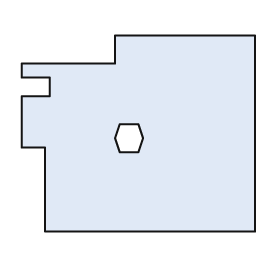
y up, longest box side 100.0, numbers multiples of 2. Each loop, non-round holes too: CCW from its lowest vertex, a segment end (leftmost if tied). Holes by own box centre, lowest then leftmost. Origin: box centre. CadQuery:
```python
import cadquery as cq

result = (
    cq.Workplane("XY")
    .moveTo(-40.0, -42.0)
    .lineTo(50.0, -42.0)
    .lineTo(50.0, 42.0)
    .lineTo(-10.0, 42.0)
    .lineTo(-10.0, 30.0)
    .lineTo(-50.0, 30.0)
    .lineTo(-50.0, 24.0)
    .lineTo(-38.0, 24.0)
    .lineTo(-38.0, 16.0)
    .lineTo(-50.0, 16.0)
    .lineTo(-50.0, -6.0)
    .lineTo(-40.0, -6.0)
    .close()
    .moveTo(-8.0, -8.0)
    .lineTo(0.0, -8.0)
    .lineTo(2.0, -2.0)
    .lineTo(0.0, 4.0)
    .lineTo(-8.0, 4.0)
    .lineTo(-10.0, -2.0)
    .close()
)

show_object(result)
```